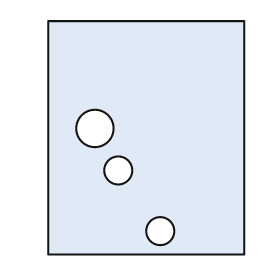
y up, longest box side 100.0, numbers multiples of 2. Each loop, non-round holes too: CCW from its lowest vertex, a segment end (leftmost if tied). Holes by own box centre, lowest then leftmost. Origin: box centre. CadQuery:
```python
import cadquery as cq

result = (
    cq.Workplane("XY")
    .moveTo(-42.0, -50.0)
    .lineTo(42.0, -50.0)
    .lineTo(42.0, 50.0)
    .lineTo(-42.0, 50.0)
    .close()
    .moveTo(6.0, -40.0)
    .circle(6.0)
    .moveTo(-12.0, -14.0)
    .circle(6.0)
    .moveTo(-22.0, 4.0)
    .circle(8.0)
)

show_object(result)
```